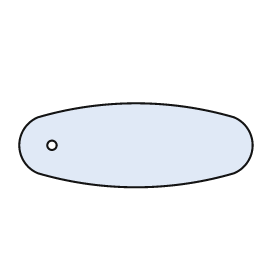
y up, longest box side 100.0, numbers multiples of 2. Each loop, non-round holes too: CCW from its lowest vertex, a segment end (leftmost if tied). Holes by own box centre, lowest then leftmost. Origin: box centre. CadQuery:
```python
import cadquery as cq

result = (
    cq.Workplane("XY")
    .moveTo(-42.0, -12.0)
    .threePointArc((0.0, -18.0), (42.0, -12.0))
    .threePointArc((50.0, 0.0), (42.0, 12.0))
    .threePointArc((0.0, 18.0), (-42.0, 12.0))
    .threePointArc((-50.0, 0.0), (-42.0, -12.0))
    .close()
    .moveTo(-36.0, 0.0)
    .circle(2.0)
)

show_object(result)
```